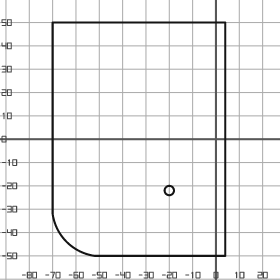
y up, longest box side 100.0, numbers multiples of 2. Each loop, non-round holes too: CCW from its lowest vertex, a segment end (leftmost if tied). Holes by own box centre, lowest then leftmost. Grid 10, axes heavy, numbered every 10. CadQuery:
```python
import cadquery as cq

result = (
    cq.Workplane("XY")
    .moveTo(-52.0, -50.0)
    .lineTo(4.0, -50.0)
    .lineTo(4.0, 50.0)
    .lineTo(-70.0, 50.0)
    .lineTo(-70.0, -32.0)
    .threePointArc((-64.0, -44.0), (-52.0, -50.0))
    .close()
    .moveTo(-20.0, -22.0)
    .circle(2.0)
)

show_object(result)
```